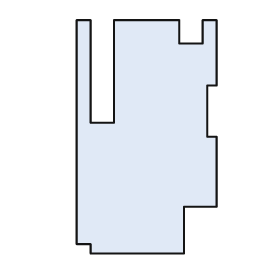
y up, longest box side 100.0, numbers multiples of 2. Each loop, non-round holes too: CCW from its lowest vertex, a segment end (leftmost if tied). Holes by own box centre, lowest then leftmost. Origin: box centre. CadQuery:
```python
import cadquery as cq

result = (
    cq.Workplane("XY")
    .moveTo(-24.0, -50.0)
    .lineTo(16.0, -50.0)
    .lineTo(16.0, -30.0)
    .lineTo(30.0, -30.0)
    .lineTo(30.0, 0.0)
    .lineTo(26.0, 0.0)
    .lineTo(26.0, 22.0)
    .lineTo(30.0, 22.0)
    .lineTo(30.0, 50.0)
    .lineTo(24.0, 50.0)
    .lineTo(24.0, 40.0)
    .lineTo(14.0, 40.0)
    .lineTo(14.0, 50.0)
    .lineTo(-14.0, 50.0)
    .lineTo(-14.0, 6.0)
    .lineTo(-24.0, 6.0)
    .lineTo(-24.0, 50.0)
    .lineTo(-30.0, 50.0)
    .lineTo(-30.0, -46.0)
    .lineTo(-24.0, -46.0)
    .close()
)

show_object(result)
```